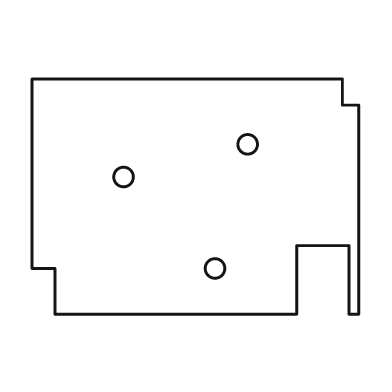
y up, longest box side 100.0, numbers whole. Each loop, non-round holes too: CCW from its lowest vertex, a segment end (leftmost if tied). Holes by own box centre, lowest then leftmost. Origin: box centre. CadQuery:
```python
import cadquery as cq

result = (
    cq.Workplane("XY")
    .moveTo(-43.0, -36.0)
    .lineTo(31.0, -36.0)
    .lineTo(31.0, -15.0)
    .lineTo(47.0, -15.0)
    .lineTo(47.0, -36.0)
    .lineTo(50.0, -36.0)
    .lineTo(50.0, 28.0)
    .lineTo(45.0, 28.0)
    .lineTo(45.0, 36.0)
    .lineTo(-50.0, 36.0)
    .lineTo(-50.0, -22.0)
    .lineTo(-43.0, -22.0)
    .close()
    .moveTo(6.0, -22.0)
    .circle(3.0)
    .moveTo(-22.0, 6.0)
    .circle(3.0)
    .moveTo(16.0, 16.0)
    .circle(3.0)
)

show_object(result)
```